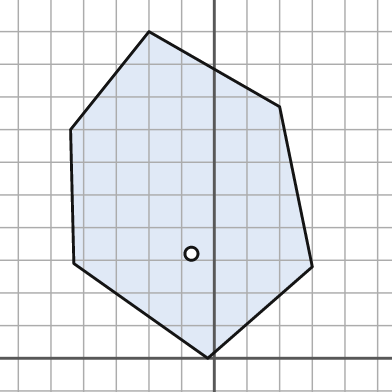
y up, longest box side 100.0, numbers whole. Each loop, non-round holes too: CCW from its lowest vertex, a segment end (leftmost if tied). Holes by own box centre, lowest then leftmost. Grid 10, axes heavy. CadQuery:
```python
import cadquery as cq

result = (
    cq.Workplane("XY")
    .moveTo(-2.0, 0.0)
    .lineTo(30.0, 28.0)
    .lineTo(20.0, 77.0)
    .lineTo(-20.0, 100.0)
    .lineTo(-44.0, 70.0)
    .lineTo(-43.0, 29.0)
    .close()
    .moveTo(-7.0, 32.0)
    .circle(2.0)
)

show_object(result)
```